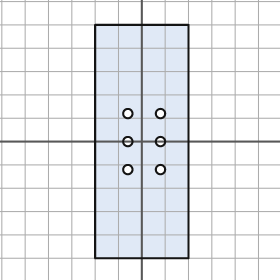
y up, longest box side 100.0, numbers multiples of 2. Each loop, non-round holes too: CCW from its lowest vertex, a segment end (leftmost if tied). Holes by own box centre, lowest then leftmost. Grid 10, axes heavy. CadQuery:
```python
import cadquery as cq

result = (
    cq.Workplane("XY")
    .moveTo(-20.0, -50.0)
    .lineTo(20.0, -50.0)
    .lineTo(20.0, 50.0)
    .lineTo(-20.0, 50.0)
    .close()
    .moveTo(-6.0, -12.0)
    .circle(2.0)
    .moveTo(8.0, -12.0)
    .circle(2.0)
    .moveTo(-6.0, 0.0)
    .circle(2.0)
    .moveTo(8.0, 0.0)
    .circle(2.0)
    .moveTo(-6.0, 12.0)
    .circle(2.0)
    .moveTo(8.0, 12.0)
    .circle(2.0)
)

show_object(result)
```